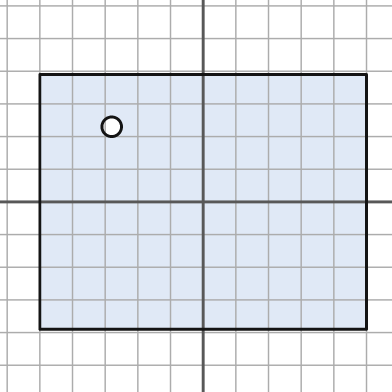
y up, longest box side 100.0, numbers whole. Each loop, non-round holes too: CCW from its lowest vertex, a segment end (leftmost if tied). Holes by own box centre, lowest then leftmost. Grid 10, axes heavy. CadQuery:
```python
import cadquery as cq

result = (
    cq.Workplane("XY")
    .moveTo(-50.0, -39.0)
    .lineTo(50.0, -39.0)
    .lineTo(50.0, 39.0)
    .lineTo(-50.0, 39.0)
    .close()
    .moveTo(-28.0, 23.0)
    .circle(3.0)
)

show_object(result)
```